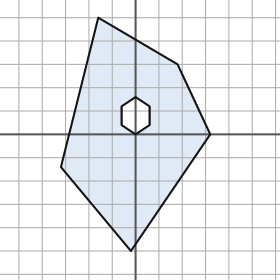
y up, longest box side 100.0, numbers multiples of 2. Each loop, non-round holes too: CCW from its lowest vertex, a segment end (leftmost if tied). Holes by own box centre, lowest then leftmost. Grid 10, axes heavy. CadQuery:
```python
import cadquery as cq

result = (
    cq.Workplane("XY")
    .moveTo(-2.0, -50.0)
    .lineTo(32.0, 0.0)
    .lineTo(18.0, 30.0)
    .lineTo(-16.0, 50.0)
    .lineTo(-32.0, -14.0)
    .close()
    .moveTo(0.0, 0.0)
    .lineTo(6.0, 4.0)
    .lineTo(6.0, 12.0)
    .lineTo(0.0, 16.0)
    .lineTo(-6.0, 12.0)
    .lineTo(-6.0, 4.0)
    .close()
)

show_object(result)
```